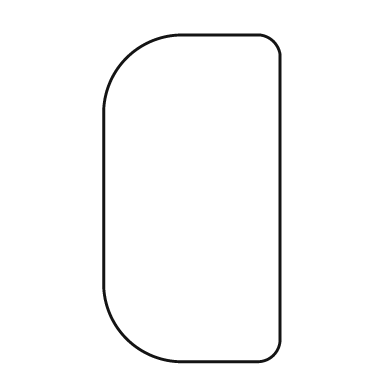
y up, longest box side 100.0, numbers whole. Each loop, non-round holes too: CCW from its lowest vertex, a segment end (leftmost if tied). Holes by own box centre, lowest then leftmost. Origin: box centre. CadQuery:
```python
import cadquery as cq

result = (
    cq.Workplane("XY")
    .moveTo(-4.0, -50.0)
    .lineTo(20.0, -50.0)
    .threePointArc((25.0, -48.0), (27.0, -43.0))
    .lineTo(27.0, 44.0)
    .threePointArc((25.0, 48.0), (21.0, 50.0))
    .lineTo(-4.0, 50.0)
    .threePointArc((-20.0, 43.0), (-27.0, 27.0))
    .lineTo(-27.0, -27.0)
    .threePointArc((-20.0, -43.0), (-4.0, -50.0))
    .close()
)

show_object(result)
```